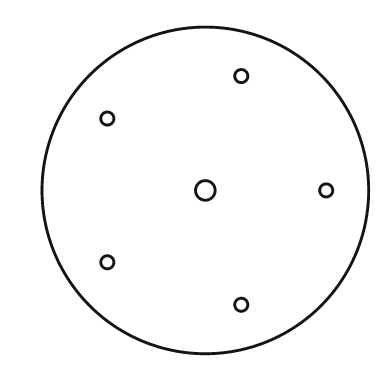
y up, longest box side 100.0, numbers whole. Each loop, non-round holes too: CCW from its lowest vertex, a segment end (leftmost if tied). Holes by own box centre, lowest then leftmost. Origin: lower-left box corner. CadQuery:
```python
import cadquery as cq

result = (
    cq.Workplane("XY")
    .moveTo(50.0, 50.0)
    .circle(50.0)
    .moveTo(61.0, 15.0)
    .circle(2.0)
    .moveTo(20.0, 28.0)
    .circle(2.0)
    .moveTo(50.0, 50.0)
    .circle(3.0)
    .moveTo(87.0, 50.0)
    .circle(2.0)
    .moveTo(20.0, 72.0)
    .circle(2.0)
    .moveTo(61.0, 85.0)
    .circle(2.0)
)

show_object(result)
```